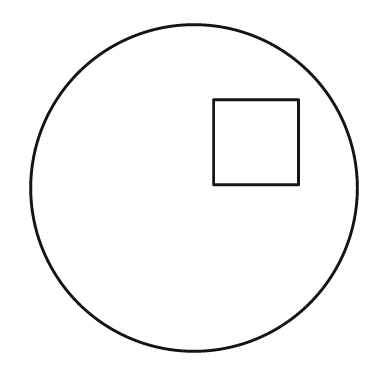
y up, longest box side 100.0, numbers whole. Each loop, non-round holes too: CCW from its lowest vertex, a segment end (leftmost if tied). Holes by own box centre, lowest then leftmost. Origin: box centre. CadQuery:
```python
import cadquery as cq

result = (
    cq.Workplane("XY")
    .moveTo(0.0, 0.0)
    .circle(50.0)
    .moveTo(6.0, 1.0)
    .lineTo(32.0, 1.0)
    .lineTo(32.0, 27.0)
    .lineTo(6.0, 27.0)
    .close()
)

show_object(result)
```